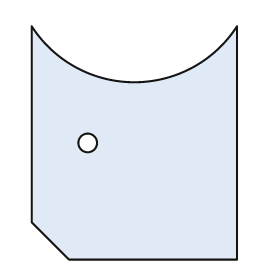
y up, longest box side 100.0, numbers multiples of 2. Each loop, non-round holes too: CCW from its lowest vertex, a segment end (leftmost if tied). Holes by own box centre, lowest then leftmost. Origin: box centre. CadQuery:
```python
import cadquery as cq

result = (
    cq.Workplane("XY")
    .moveTo(-28.0, -50.0)
    .lineTo(44.0, -50.0)
    .lineTo(44.0, 50.0)
    .threePointArc((0.0, 26.0), (-44.0, 50.0))
    .lineTo(-44.0, -34.0)
    .close()
    .moveTo(-20.0, 0.0)
    .circle(4.0)
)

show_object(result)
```